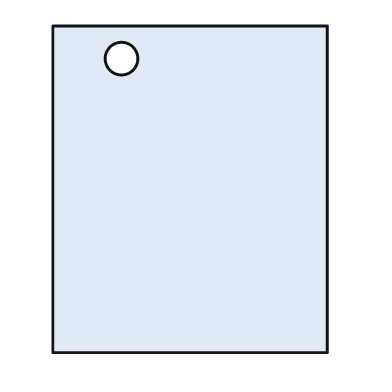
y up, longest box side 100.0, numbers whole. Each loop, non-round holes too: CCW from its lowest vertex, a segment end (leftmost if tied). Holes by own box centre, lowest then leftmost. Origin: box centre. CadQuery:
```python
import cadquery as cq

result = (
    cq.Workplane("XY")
    .moveTo(-42.0, -50.0)
    .lineTo(42.0, -50.0)
    .lineTo(42.0, 50.0)
    .lineTo(-42.0, 50.0)
    .close()
    .moveTo(-21.0, 40.0)
    .circle(5.0)
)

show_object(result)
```